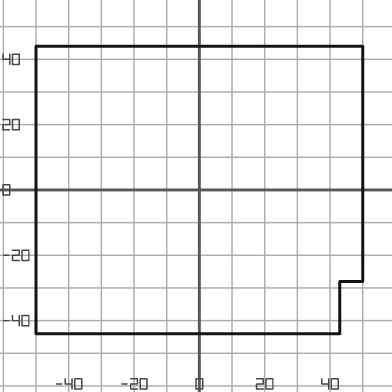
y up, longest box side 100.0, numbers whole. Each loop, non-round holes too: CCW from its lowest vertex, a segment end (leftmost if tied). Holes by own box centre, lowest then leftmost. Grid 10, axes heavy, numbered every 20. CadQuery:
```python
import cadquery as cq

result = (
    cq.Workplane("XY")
    .moveTo(-50.0, -44.0)
    .lineTo(43.0, -44.0)
    .lineTo(43.0, -28.0)
    .lineTo(50.0, -28.0)
    .lineTo(50.0, 44.0)
    .lineTo(-50.0, 44.0)
    .close()
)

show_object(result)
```